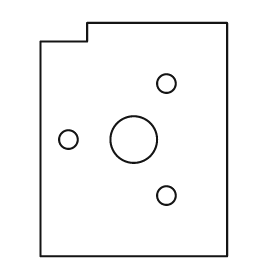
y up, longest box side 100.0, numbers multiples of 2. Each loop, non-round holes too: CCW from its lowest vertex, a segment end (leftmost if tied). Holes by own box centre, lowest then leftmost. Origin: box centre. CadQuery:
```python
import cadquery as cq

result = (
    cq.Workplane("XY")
    .moveTo(-40.0, -50.0)
    .lineTo(40.0, -50.0)
    .lineTo(40.0, 50.0)
    .lineTo(-20.0, 50.0)
    .lineTo(-20.0, 42.0)
    .lineTo(-40.0, 42.0)
    .close()
    .moveTo(14.0, -24.0)
    .circle(4.0)
    .moveTo(-28.0, 0.0)
    .circle(4.0)
    .moveTo(0.0, 0.0)
    .circle(10.0)
    .moveTo(14.0, 24.0)
    .circle(4.0)
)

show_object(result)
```